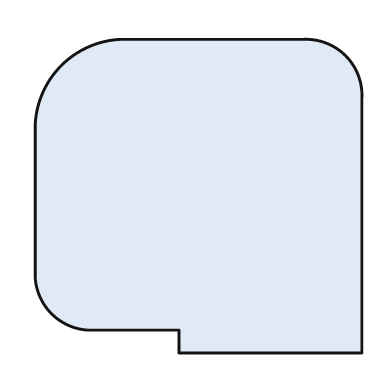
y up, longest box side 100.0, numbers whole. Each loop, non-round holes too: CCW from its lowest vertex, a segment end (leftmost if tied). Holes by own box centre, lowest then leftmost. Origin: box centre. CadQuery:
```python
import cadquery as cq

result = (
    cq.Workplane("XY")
    .moveTo(-6.0, -48.0)
    .lineTo(50.0, -48.0)
    .lineTo(50.0, 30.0)
    .threePointArc((45.0, 43.0), (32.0, 48.0))
    .lineTo(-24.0, 48.0)
    .threePointArc((-42.0, 40.0), (-50.0, 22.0))
    .lineTo(-50.0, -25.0)
    .threePointArc((-45.0, -36.0), (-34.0, -41.0))
    .lineTo(-6.0, -41.0)
    .close()
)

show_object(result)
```